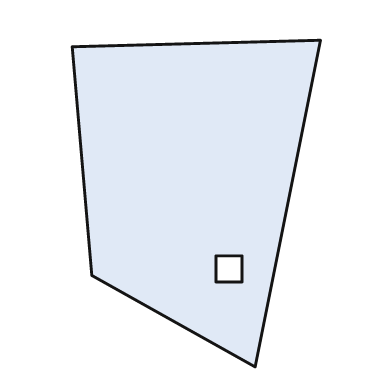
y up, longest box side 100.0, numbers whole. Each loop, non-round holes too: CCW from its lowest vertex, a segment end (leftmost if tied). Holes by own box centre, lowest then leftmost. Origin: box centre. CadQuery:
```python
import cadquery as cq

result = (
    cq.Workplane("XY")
    .moveTo(18.0, -50.0)
    .lineTo(38.0, 50.0)
    .lineTo(-38.0, 48.0)
    .lineTo(-32.0, -22.0)
    .close()
    .moveTo(6.0, -24.0)
    .lineTo(14.0, -24.0)
    .lineTo(14.0, -16.0)
    .lineTo(6.0, -16.0)
    .close()
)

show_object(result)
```